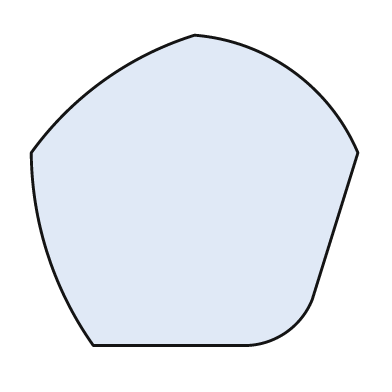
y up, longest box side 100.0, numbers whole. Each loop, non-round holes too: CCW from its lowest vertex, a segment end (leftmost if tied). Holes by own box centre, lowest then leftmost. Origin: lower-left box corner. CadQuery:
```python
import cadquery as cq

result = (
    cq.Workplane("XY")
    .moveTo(19.0, 0.0)
    .lineTo(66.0, 0.0)
    .threePointArc((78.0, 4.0), (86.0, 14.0))
    .lineTo(100.0, 59.0)
    .threePointArc((80.0, 84.0), (50.0, 95.0))
    .threePointArc((22.0, 81.0), (0.0, 59.0))
    .threePointArc((5.0, 28.0), (19.0, 0.0))
    .close()
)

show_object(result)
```